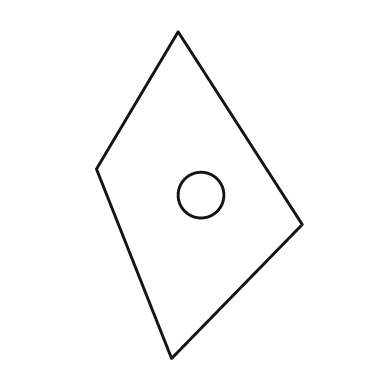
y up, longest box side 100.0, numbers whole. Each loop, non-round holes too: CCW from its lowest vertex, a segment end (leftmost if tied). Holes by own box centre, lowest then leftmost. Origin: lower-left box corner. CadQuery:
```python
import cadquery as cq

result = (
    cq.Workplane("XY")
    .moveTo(23.0, 0.0)
    .lineTo(63.0, 41.0)
    .lineTo(25.0, 100.0)
    .lineTo(0.0, 58.0)
    .close()
    .moveTo(32.0, 50.0)
    .circle(7.0)
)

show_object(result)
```